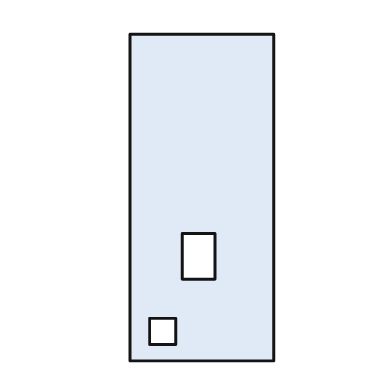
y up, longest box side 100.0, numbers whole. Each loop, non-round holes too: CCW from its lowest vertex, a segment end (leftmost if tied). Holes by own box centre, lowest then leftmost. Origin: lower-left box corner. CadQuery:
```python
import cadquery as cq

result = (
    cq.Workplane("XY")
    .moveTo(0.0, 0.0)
    .lineTo(44.0, 0.0)
    .lineTo(44.0, 100.0)
    .lineTo(0.0, 100.0)
    .close()
    .moveTo(6.0, 5.0)
    .lineTo(14.0, 5.0)
    .lineTo(14.0, 13.0)
    .lineTo(6.0, 13.0)
    .close()
    .moveTo(16.0, 25.0)
    .lineTo(26.0, 25.0)
    .lineTo(26.0, 39.0)
    .lineTo(16.0, 39.0)
    .close()
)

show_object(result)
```